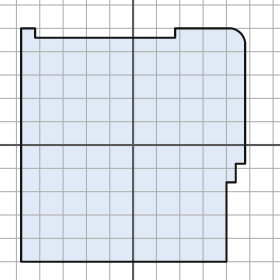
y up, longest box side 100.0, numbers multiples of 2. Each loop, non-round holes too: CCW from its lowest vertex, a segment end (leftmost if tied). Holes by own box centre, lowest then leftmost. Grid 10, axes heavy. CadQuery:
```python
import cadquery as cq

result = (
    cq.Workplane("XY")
    .moveTo(-48.0, -50.0)
    .lineTo(40.0, -50.0)
    .lineTo(40.0, -16.0)
    .lineTo(44.0, -16.0)
    .lineTo(44.0, -8.0)
    .lineTo(48.0, -8.0)
    .lineTo(48.0, 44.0)
    .threePointArc((46.0, 48.0), (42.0, 50.0))
    .lineTo(18.0, 50.0)
    .lineTo(18.0, 46.0)
    .lineTo(-42.0, 46.0)
    .lineTo(-42.0, 50.0)
    .lineTo(-48.0, 50.0)
    .close()
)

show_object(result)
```